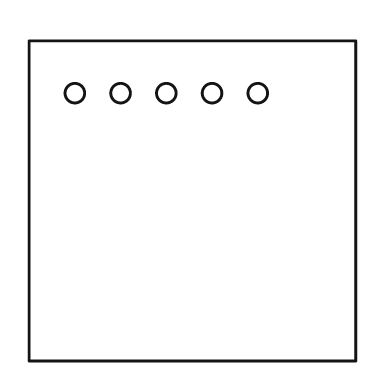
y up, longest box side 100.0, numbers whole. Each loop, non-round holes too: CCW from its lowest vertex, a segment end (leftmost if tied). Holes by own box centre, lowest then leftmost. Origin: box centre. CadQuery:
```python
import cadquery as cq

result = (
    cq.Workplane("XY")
    .moveTo(-50.0, -49.0)
    .lineTo(50.0, -49.0)
    .lineTo(50.0, 49.0)
    .lineTo(-50.0, 49.0)
    .close()
    .moveTo(-36.0, 33.0)
    .circle(3.0)
    .moveTo(-22.0, 33.0)
    .circle(3.0)
    .moveTo(-8.0, 33.0)
    .circle(3.0)
    .moveTo(6.0, 33.0)
    .circle(3.0)
    .moveTo(20.0, 33.0)
    .circle(3.0)
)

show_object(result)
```